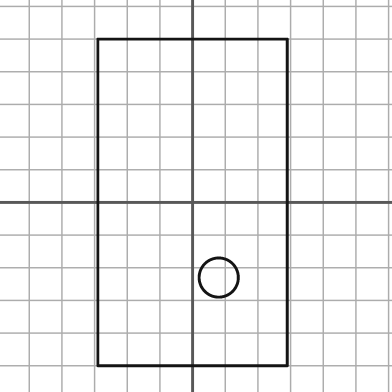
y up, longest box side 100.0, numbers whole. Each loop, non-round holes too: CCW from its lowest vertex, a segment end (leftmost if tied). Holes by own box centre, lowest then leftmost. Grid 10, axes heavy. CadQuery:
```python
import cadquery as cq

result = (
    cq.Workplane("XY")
    .moveTo(-29.0, -50.0)
    .lineTo(29.0, -50.0)
    .lineTo(29.0, 50.0)
    .lineTo(-29.0, 50.0)
    .close()
    .moveTo(8.0, -23.0)
    .circle(6.0)
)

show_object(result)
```